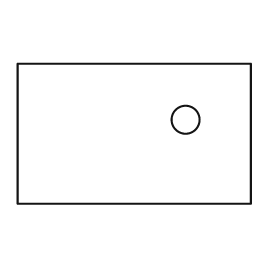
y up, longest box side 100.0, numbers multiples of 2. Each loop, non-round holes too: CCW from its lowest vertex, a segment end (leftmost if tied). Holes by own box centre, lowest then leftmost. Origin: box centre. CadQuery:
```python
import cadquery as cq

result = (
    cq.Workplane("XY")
    .moveTo(-50.0, -30.0)
    .lineTo(50.0, -30.0)
    .lineTo(50.0, 30.0)
    .lineTo(-50.0, 30.0)
    .close()
    .moveTo(22.0, 6.0)
    .circle(6.0)
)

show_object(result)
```